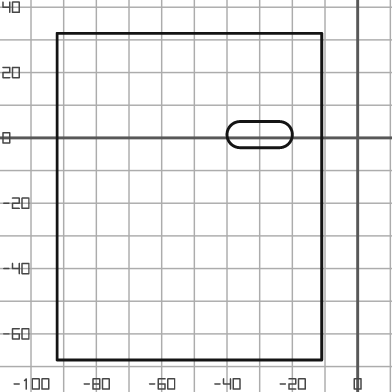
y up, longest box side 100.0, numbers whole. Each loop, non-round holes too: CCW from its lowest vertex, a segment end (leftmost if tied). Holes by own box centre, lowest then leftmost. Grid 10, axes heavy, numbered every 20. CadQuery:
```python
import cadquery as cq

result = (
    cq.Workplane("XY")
    .moveTo(-92.0, -68.0)
    .lineTo(-11.0, -68.0)
    .lineTo(-11.0, 32.0)
    .lineTo(-92.0, 32.0)
    .close()
    .moveTo(-36.0, -3.0)
    .lineTo(-24.0, -3.0)
    .threePointArc((-20.0, 1.0), (-24.0, 5.0))
    .lineTo(-36.0, 5.0)
    .threePointArc((-40.0, 1.0), (-36.0, -3.0))
    .close()
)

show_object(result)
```